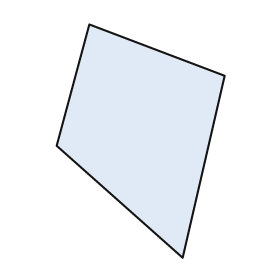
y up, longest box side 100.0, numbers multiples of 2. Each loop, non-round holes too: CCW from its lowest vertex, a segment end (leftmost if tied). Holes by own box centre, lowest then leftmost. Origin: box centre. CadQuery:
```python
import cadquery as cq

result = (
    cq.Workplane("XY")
    .moveTo(18.0, -50.0)
    .lineTo(36.0, 28.0)
    .lineTo(-22.0, 50.0)
    .lineTo(-36.0, -2.0)
    .close()
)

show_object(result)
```